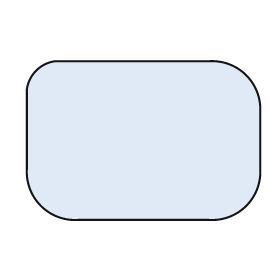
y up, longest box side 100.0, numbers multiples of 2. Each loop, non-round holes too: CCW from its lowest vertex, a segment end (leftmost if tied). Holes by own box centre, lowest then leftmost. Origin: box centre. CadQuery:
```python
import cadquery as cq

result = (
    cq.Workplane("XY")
    .moveTo(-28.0, -34.0)
    .lineTo(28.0, -34.0)
    .threePointArc((44.0, -28.0), (50.0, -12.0))
    .lineTo(50.0, 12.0)
    .threePointArc((44.0, 28.0), (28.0, 34.0))
    .lineTo(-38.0, 34.0)
    .threePointArc((-46.0, 30.0), (-50.0, 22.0))
    .lineTo(-50.0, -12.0)
    .threePointArc((-44.0, -28.0), (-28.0, -34.0))
    .close()
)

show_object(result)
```